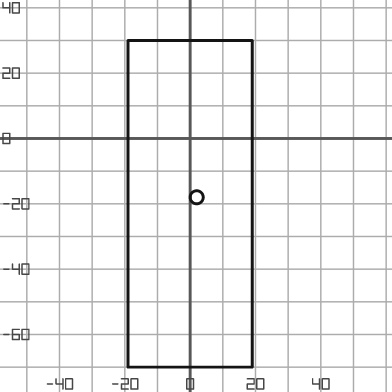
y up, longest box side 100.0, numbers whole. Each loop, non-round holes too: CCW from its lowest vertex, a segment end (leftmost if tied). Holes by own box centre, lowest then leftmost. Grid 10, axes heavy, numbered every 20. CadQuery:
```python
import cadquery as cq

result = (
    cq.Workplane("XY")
    .moveTo(-19.0, -70.0)
    .lineTo(19.0, -70.0)
    .lineTo(19.0, 30.0)
    .lineTo(-19.0, 30.0)
    .close()
    .moveTo(2.0, -18.0)
    .circle(2.0)
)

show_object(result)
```